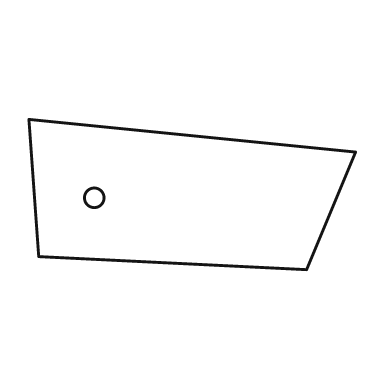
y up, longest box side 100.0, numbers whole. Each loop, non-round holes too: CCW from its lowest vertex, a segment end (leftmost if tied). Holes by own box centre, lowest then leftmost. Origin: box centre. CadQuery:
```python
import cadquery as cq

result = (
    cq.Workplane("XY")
    .moveTo(35.0, -23.0)
    .lineTo(50.0, 13.0)
    .lineTo(-50.0, 23.0)
    .lineTo(-47.0, -19.0)
    .close()
    .moveTo(-30.0, -1.0)
    .circle(3.0)
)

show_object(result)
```